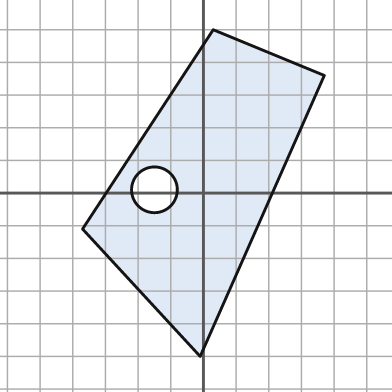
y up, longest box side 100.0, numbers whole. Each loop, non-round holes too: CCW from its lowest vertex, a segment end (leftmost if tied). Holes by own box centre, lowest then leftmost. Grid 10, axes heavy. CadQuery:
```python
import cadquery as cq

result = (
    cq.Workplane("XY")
    .moveTo(-1.0, -50.0)
    .lineTo(37.0, 36.0)
    .lineTo(3.0, 50.0)
    .lineTo(-37.0, -11.0)
    .close()
    .moveTo(-15.0, 1.0)
    .circle(7.0)
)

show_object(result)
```